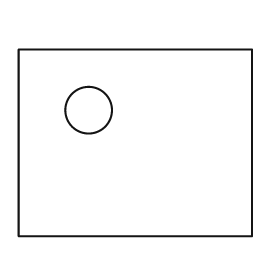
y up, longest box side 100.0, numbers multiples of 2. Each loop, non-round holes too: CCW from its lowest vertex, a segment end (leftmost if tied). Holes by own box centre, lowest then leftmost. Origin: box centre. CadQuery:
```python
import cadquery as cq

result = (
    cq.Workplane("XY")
    .moveTo(-50.0, -40.0)
    .lineTo(50.0, -40.0)
    .lineTo(50.0, 40.0)
    .lineTo(-50.0, 40.0)
    .close()
    .moveTo(-20.0, 14.0)
    .circle(10.0)
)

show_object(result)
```